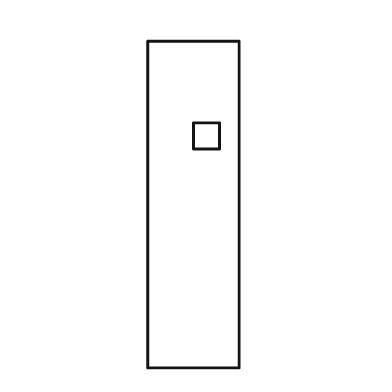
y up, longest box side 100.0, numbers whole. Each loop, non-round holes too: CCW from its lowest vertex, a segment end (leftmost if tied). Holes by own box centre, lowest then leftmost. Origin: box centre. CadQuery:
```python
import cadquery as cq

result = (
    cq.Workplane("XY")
    .moveTo(-14.0, -50.0)
    .lineTo(14.0, -50.0)
    .lineTo(14.0, 50.0)
    .lineTo(-14.0, 50.0)
    .close()
    .moveTo(0.0, 17.0)
    .lineTo(8.0, 17.0)
    .lineTo(8.0, 25.0)
    .lineTo(0.0, 25.0)
    .close()
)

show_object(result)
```